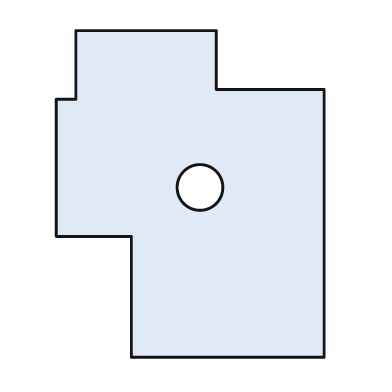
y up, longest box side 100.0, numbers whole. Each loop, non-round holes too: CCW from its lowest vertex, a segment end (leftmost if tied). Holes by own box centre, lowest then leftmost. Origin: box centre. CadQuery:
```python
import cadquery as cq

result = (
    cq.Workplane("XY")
    .moveTo(-18.0, -50.0)
    .lineTo(41.0, -50.0)
    .lineTo(41.0, 32.0)
    .lineTo(8.0, 32.0)
    .lineTo(8.0, 50.0)
    .lineTo(-35.0, 50.0)
    .lineTo(-35.0, 29.0)
    .lineTo(-41.0, 29.0)
    .lineTo(-41.0, -13.0)
    .lineTo(-18.0, -13.0)
    .close()
    .moveTo(3.0, 2.0)
    .circle(7.0)
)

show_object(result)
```